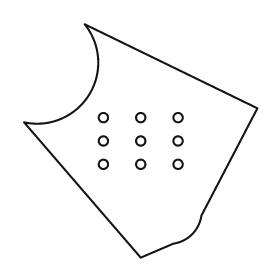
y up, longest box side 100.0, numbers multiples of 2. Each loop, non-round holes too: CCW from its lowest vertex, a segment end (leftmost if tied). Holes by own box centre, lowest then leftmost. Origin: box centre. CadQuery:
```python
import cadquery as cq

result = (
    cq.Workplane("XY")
    .moveTo(0.0, -50.0)
    .lineTo(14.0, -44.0)
    .threePointArc((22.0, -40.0), (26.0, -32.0))
    .lineTo(50.0, 14.0)
    .lineTo(-24.0, 50.0)
    .threePointArc((-22.0, 20.0), (-50.0, 8.0))
    .close()
    .moveTo(-16.0, -10.0)
    .circle(2.0)
    .moveTo(0.0, -10.0)
    .circle(2.0)
    .moveTo(16.0, -10.0)
    .circle(2.0)
    .moveTo(-16.0, 0.0)
    .circle(2.0)
    .moveTo(0.0, 0.0)
    .circle(2.0)
    .moveTo(16.0, 0.0)
    .circle(2.0)
    .moveTo(-16.0, 10.0)
    .circle(2.0)
    .moveTo(0.0, 10.0)
    .circle(2.0)
    .moveTo(16.0, 10.0)
    .circle(2.0)
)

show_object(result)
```